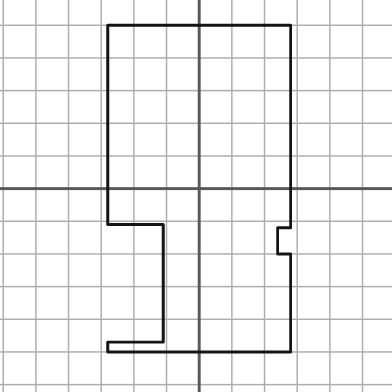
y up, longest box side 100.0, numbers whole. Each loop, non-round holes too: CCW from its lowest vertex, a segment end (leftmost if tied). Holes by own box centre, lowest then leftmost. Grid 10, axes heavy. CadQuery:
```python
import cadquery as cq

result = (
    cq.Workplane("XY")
    .moveTo(-28.0, -50.0)
    .lineTo(28.0, -50.0)
    .lineTo(28.0, -20.0)
    .lineTo(24.0, -20.0)
    .lineTo(24.0, -12.0)
    .lineTo(28.0, -12.0)
    .lineTo(28.0, 50.0)
    .lineTo(-28.0, 50.0)
    .lineTo(-28.0, -11.0)
    .lineTo(-11.0, -11.0)
    .lineTo(-11.0, -47.0)
    .lineTo(-28.0, -47.0)
    .close()
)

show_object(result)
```